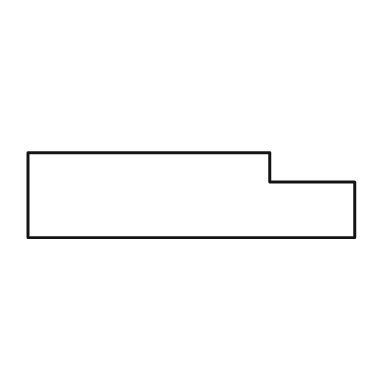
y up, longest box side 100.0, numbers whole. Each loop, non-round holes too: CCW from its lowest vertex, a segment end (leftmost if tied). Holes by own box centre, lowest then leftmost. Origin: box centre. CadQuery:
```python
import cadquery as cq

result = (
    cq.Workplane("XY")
    .moveTo(-50.0, -13.0)
    .lineTo(50.0, -13.0)
    .lineTo(50.0, 4.0)
    .lineTo(24.0, 4.0)
    .lineTo(24.0, 13.0)
    .lineTo(-50.0, 13.0)
    .close()
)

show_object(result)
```